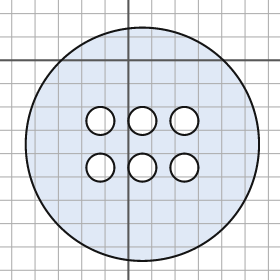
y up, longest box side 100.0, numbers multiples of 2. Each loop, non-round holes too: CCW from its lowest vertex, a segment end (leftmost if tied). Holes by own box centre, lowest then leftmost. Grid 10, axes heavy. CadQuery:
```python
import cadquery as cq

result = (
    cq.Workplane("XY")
    .moveTo(6.0, -36.0)
    .circle(50.0)
    .moveTo(-12.0, -46.0)
    .circle(6.0)
    .moveTo(6.0, -46.0)
    .circle(6.0)
    .moveTo(24.0, -46.0)
    .circle(6.0)
    .moveTo(-12.0, -26.0)
    .circle(6.0)
    .moveTo(6.0, -26.0)
    .circle(6.0)
    .moveTo(24.0, -26.0)
    .circle(6.0)
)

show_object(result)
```